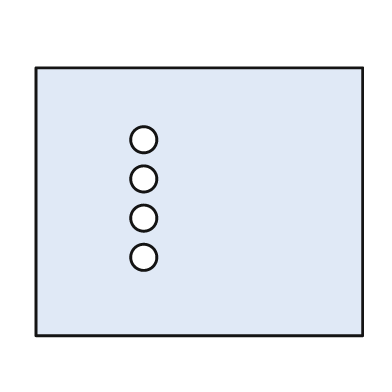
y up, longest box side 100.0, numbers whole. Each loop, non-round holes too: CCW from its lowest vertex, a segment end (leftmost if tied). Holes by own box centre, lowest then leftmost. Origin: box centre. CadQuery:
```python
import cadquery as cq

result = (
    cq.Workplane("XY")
    .moveTo(-50.0, -41.0)
    .lineTo(50.0, -41.0)
    .lineTo(50.0, 41.0)
    .lineTo(-50.0, 41.0)
    .close()
    .moveTo(-17.0, -17.0)
    .circle(4.0)
    .moveTo(-17.0, -5.0)
    .circle(4.0)
    .moveTo(-17.0, 7.0)
    .circle(4.0)
    .moveTo(-17.0, 19.0)
    .circle(4.0)
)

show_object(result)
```